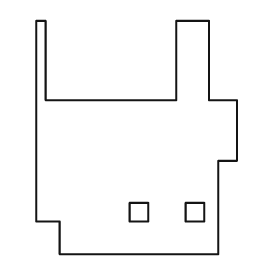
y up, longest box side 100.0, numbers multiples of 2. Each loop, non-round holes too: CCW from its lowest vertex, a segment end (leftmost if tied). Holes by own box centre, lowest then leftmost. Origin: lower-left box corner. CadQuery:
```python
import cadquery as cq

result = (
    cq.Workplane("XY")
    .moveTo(10.0, 0.0)
    .lineTo(78.0, 0.0)
    .lineTo(78.0, 40.0)
    .lineTo(86.0, 40.0)
    .lineTo(86.0, 66.0)
    .lineTo(74.0, 66.0)
    .lineTo(74.0, 100.0)
    .lineTo(60.0, 100.0)
    .lineTo(60.0, 66.0)
    .lineTo(4.0, 66.0)
    .lineTo(4.0, 100.0)
    .lineTo(0.0, 100.0)
    .lineTo(0.0, 14.0)
    .lineTo(10.0, 14.0)
    .close()
    .moveTo(40.0, 14.0)
    .lineTo(48.0, 14.0)
    .lineTo(48.0, 22.0)
    .lineTo(40.0, 22.0)
    .close()
    .moveTo(64.0, 14.0)
    .lineTo(72.0, 14.0)
    .lineTo(72.0, 22.0)
    .lineTo(64.0, 22.0)
    .close()
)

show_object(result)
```